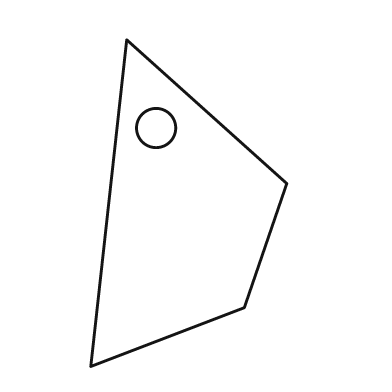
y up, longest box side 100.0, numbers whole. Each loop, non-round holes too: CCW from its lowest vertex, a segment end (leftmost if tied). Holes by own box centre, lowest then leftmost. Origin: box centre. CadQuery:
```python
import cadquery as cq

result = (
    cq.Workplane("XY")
    .moveTo(-30.0, -50.0)
    .lineTo(17.0, -32.0)
    .lineTo(30.0, 6.0)
    .lineTo(-19.0, 50.0)
    .close()
    .moveTo(-10.0, 23.0)
    .circle(6.0)
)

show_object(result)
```